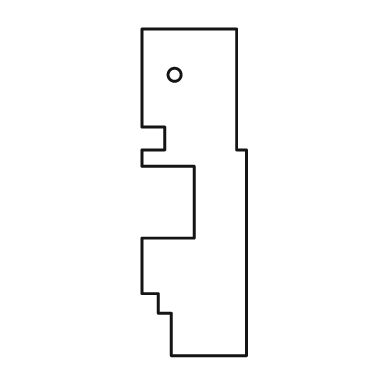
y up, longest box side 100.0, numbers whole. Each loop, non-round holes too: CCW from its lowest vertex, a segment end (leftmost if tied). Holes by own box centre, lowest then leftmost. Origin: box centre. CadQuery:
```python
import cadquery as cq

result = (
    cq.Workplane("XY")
    .moveTo(-7.0, -50.0)
    .lineTo(16.0, -50.0)
    .lineTo(16.0, 13.0)
    .lineTo(13.0, 13.0)
    .lineTo(13.0, 50.0)
    .lineTo(-16.0, 50.0)
    .lineTo(-16.0, 20.0)
    .lineTo(-9.0, 20.0)
    .lineTo(-9.0, 13.0)
    .lineTo(-16.0, 13.0)
    .lineTo(-16.0, 8.0)
    .lineTo(0.0, 8.0)
    .lineTo(0.0, -14.0)
    .lineTo(-16.0, -14.0)
    .lineTo(-16.0, -31.0)
    .lineTo(-11.0, -31.0)
    .lineTo(-11.0, -37.0)
    .lineTo(-7.0, -37.0)
    .close()
    .moveTo(-6.0, 36.0)
    .circle(2.0)
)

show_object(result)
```